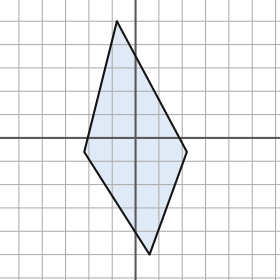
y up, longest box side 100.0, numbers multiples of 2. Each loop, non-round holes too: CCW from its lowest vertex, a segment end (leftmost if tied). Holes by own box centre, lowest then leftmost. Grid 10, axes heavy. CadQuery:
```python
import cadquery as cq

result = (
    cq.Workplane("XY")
    .moveTo(6.0, -50.0)
    .lineTo(22.0, -6.0)
    .lineTo(-8.0, 50.0)
    .lineTo(-22.0, -6.0)
    .close()
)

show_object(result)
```